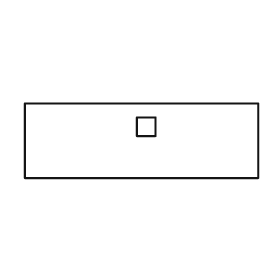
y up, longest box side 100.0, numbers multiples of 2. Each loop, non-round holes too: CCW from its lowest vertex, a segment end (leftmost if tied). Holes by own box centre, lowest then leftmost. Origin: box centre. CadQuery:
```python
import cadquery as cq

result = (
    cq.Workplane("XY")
    .moveTo(-50.0, -16.0)
    .lineTo(50.0, -16.0)
    .lineTo(50.0, 16.0)
    .lineTo(-50.0, 16.0)
    .close()
    .moveTo(-2.0, 2.0)
    .lineTo(6.0, 2.0)
    .lineTo(6.0, 10.0)
    .lineTo(-2.0, 10.0)
    .close()
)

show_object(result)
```